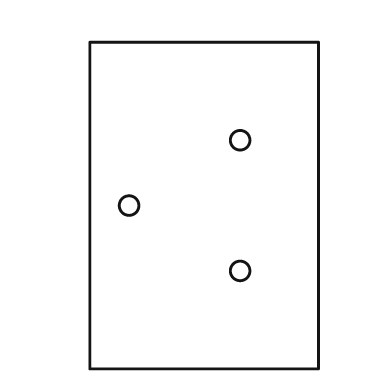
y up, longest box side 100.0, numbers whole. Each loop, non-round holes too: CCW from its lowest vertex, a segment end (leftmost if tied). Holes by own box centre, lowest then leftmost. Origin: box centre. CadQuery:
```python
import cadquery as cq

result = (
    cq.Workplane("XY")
    .moveTo(-35.0, -50.0)
    .lineTo(35.0, -50.0)
    .lineTo(35.0, 50.0)
    .lineTo(-35.0, 50.0)
    .close()
    .moveTo(11.0, -20.0)
    .circle(3.0)
    .moveTo(-23.0, 0.0)
    .circle(3.0)
    .moveTo(11.0, 20.0)
    .circle(3.0)
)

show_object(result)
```